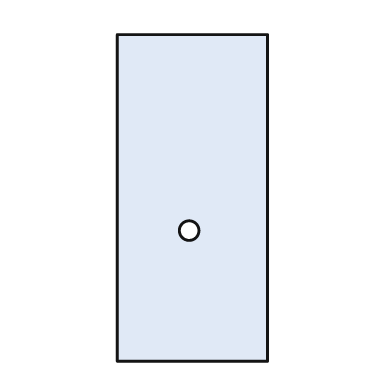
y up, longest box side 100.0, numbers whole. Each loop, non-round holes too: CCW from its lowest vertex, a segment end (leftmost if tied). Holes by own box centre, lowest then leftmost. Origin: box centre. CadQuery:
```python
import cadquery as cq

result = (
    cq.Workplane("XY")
    .moveTo(-23.0, -50.0)
    .lineTo(23.0, -50.0)
    .lineTo(23.0, 50.0)
    .lineTo(-23.0, 50.0)
    .close()
    .moveTo(-1.0, -10.0)
    .circle(3.0)
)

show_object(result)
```